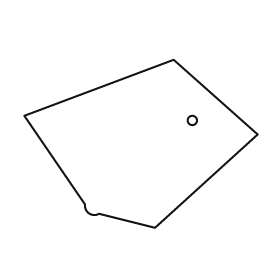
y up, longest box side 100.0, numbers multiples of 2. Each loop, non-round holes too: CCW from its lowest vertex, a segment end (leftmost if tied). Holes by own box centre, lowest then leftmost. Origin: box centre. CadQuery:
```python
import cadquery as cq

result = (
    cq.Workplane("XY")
    .moveTo(6.0, -36.0)
    .lineTo(50.0, 4.0)
    .lineTo(14.0, 36.0)
    .lineTo(-50.0, 12.0)
    .lineTo(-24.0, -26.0)
    .threePointArc((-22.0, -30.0), (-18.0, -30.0))
    .close()
    .moveTo(22.0, 10.0)
    .circle(2.0)
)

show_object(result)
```